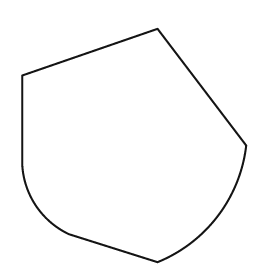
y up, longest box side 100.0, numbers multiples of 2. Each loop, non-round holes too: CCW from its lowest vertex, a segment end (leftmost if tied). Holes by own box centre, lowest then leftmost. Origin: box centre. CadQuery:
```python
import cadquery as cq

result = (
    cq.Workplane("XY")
    .moveTo(10.0, -50.0)
    .threePointArc((36.0, -30.0), (48.0, 0.0))
    .lineTo(10.0, 50.0)
    .lineTo(-48.0, 30.0)
    .lineTo(-48.0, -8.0)
    .threePointArc((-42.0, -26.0), (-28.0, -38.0))
    .close()
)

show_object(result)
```